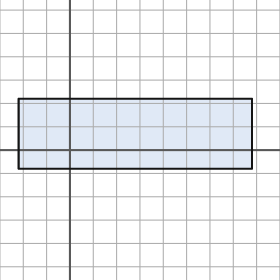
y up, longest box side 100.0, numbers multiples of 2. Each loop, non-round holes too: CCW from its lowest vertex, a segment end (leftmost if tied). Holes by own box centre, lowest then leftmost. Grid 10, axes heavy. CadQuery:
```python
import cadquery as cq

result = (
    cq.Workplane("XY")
    .moveTo(-22.0, -8.0)
    .lineTo(78.0, -8.0)
    .lineTo(78.0, 22.0)
    .lineTo(-22.0, 22.0)
    .close()
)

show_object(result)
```